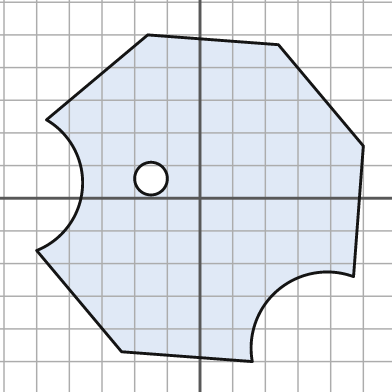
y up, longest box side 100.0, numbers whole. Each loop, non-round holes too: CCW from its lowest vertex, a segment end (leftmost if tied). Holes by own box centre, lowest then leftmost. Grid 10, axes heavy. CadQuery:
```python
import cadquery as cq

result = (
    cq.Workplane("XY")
    .moveTo(16.0, -50.0)
    .threePointArc((24.0, -28.0), (47.0, -24.0))
    .lineTo(50.0, 16.0)
    .lineTo(24.0, 47.0)
    .lineTo(-16.0, 50.0)
    .lineTo(-47.0, 24.0)
    .threePointArc((-36.0, 3.0), (-50.0, -16.0))
    .lineTo(-24.0, -47.0)
    .close()
    .moveTo(-15.0, 6.0)
    .circle(5.0)
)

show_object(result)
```